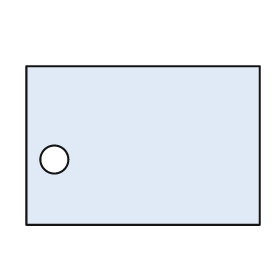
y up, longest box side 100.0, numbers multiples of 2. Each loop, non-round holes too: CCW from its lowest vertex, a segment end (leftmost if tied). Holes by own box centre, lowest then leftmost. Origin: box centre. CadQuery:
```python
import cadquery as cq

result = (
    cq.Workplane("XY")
    .moveTo(-50.0, -34.0)
    .lineTo(50.0, -34.0)
    .lineTo(50.0, 34.0)
    .lineTo(-50.0, 34.0)
    .close()
    .moveTo(-38.0, -6.0)
    .circle(6.0)
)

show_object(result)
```